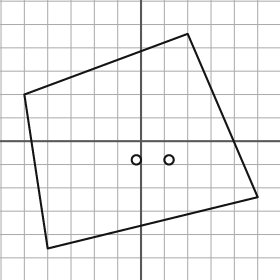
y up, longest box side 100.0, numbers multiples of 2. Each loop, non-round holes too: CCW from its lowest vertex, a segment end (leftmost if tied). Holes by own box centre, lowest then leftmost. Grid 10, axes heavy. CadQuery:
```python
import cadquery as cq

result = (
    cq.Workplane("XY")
    .moveTo(-40.0, -46.0)
    .lineTo(50.0, -24.0)
    .lineTo(20.0, 46.0)
    .lineTo(-50.0, 20.0)
    .close()
    .moveTo(-2.0, -8.0)
    .circle(2.0)
    .moveTo(12.0, -8.0)
    .circle(2.0)
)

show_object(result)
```